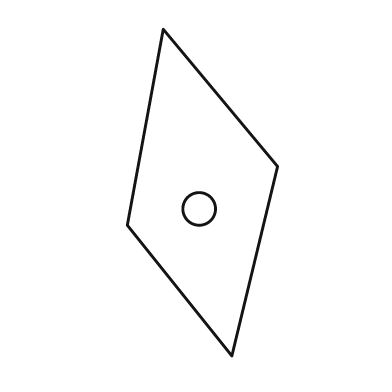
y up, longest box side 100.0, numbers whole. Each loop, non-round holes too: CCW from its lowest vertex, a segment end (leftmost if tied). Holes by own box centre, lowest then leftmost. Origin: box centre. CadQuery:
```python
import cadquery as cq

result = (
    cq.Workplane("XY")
    .moveTo(9.0, -50.0)
    .lineTo(23.0, 8.0)
    .lineTo(-12.0, 50.0)
    .lineTo(-23.0, -10.0)
    .close()
    .moveTo(-1.0, -5.0)
    .circle(5.0)
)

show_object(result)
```